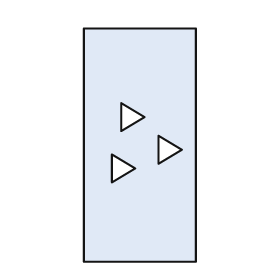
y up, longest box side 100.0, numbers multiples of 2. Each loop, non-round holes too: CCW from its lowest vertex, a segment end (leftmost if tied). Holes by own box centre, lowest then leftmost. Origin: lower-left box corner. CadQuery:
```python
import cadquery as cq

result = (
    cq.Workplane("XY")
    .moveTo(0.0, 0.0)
    .lineTo(48.0, 0.0)
    .lineTo(48.0, 100.0)
    .lineTo(0.0, 100.0)
    .close()
    .moveTo(12.0, 34.0)
    .lineTo(22.0, 40.0)
    .lineTo(12.0, 46.0)
    .close()
    .moveTo(32.0, 42.0)
    .lineTo(42.0, 48.0)
    .lineTo(32.0, 54.0)
    .close()
    .moveTo(16.0, 56.0)
    .lineTo(26.0, 62.0)
    .lineTo(16.0, 68.0)
    .close()
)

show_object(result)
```